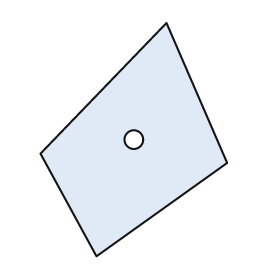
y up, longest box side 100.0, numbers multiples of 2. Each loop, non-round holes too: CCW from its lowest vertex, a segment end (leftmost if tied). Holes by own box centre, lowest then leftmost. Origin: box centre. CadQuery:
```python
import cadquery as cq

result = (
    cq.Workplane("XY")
    .moveTo(-16.0, -50.0)
    .lineTo(40.0, -10.0)
    .lineTo(14.0, 50.0)
    .lineTo(-40.0, -6.0)
    .close()
    .moveTo(0.0, 0.0)
    .circle(4.0)
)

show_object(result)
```